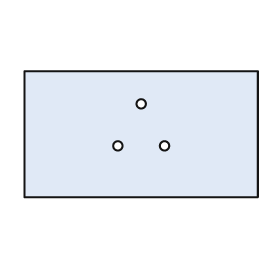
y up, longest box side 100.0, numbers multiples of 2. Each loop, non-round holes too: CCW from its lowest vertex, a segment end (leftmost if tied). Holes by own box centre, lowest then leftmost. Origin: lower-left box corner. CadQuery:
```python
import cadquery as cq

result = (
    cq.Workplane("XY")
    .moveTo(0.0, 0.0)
    .lineTo(100.0, 0.0)
    .lineTo(100.0, 54.0)
    .lineTo(0.0, 54.0)
    .close()
    .moveTo(40.0, 22.0)
    .circle(2.0)
    .moveTo(60.0, 22.0)
    .circle(2.0)
    .moveTo(50.0, 40.0)
    .circle(2.0)
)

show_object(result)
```